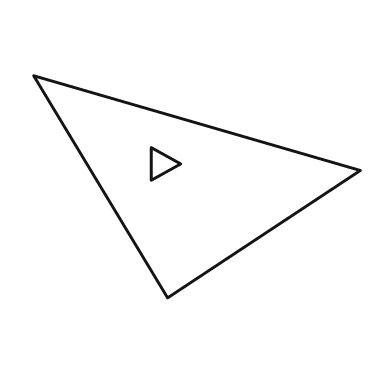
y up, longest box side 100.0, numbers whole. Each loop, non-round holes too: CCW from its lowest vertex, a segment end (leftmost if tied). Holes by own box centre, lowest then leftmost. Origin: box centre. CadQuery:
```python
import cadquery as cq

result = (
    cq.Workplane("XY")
    .moveTo(-9.0, -34.0)
    .lineTo(50.0, 5.0)
    .lineTo(-50.0, 34.0)
    .close()
    .moveTo(-14.0, 2.0)
    .lineTo(-5.0, 7.0)
    .lineTo(-14.0, 12.0)
    .close()
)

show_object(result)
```